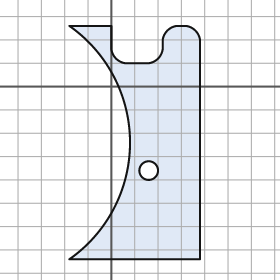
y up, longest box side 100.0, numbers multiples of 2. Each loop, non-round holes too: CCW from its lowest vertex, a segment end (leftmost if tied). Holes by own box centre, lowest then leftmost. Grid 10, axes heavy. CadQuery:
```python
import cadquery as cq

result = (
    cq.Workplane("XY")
    .moveTo(-18.0, -74.0)
    .lineTo(38.0, -74.0)
    .lineTo(38.0, 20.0)
    .threePointArc((36.0, 24.0), (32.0, 26.0))
    .lineTo(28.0, 26.0)
    .threePointArc((24.0, 24.0), (22.0, 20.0))
    .lineTo(22.0, 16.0)
    .threePointArc((20.0, 12.0), (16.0, 10.0))
    .lineTo(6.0, 10.0)
    .threePointArc((2.0, 12.0), (0.0, 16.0))
    .lineTo(0.0, 26.0)
    .lineTo(-18.0, 26.0)
    .threePointArc((8.0, -24.0), (-18.0, -74.0))
    .close()
    .moveTo(16.0, -36.0)
    .circle(4.0)
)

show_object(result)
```